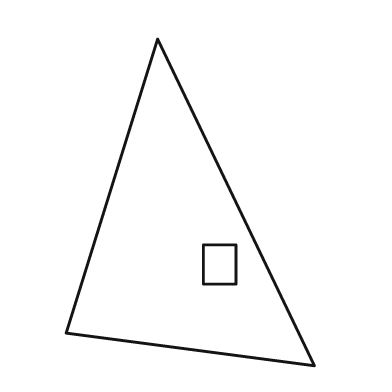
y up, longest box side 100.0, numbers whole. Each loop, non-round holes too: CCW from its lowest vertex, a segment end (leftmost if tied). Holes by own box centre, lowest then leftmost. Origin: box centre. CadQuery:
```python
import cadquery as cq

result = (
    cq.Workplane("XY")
    .moveTo(38.0, -50.0)
    .lineTo(-10.0, 50.0)
    .lineTo(-38.0, -40.0)
    .close()
    .moveTo(4.0, -25.0)
    .lineTo(14.0, -25.0)
    .lineTo(14.0, -13.0)
    .lineTo(4.0, -13.0)
    .close()
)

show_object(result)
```